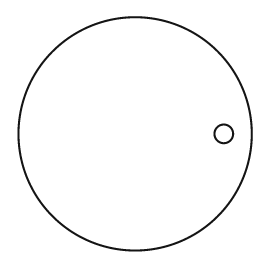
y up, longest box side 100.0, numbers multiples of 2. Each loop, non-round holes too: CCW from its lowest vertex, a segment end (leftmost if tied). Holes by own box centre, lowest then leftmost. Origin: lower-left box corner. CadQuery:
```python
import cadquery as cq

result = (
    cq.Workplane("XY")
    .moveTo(50.0, 50.0)
    .circle(50.0)
    .moveTo(88.0, 50.0)
    .circle(4.0)
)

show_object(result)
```